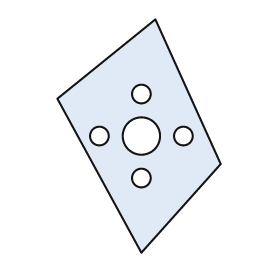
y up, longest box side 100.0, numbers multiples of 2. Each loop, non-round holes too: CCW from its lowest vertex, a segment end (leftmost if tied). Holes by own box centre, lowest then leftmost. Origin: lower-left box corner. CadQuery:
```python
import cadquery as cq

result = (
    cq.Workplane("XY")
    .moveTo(36.0, 0.0)
    .lineTo(70.0, 38.0)
    .lineTo(42.0, 100.0)
    .lineTo(0.0, 66.0)
    .close()
    .moveTo(36.0, 32.0)
    .circle(4.0)
    .moveTo(18.0, 50.0)
    .circle(4.0)
    .moveTo(36.0, 50.0)
    .circle(8.0)
    .moveTo(54.0, 50.0)
    .circle(4.0)
    .moveTo(36.0, 68.0)
    .circle(4.0)
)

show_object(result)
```